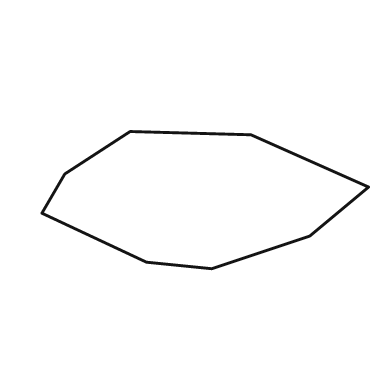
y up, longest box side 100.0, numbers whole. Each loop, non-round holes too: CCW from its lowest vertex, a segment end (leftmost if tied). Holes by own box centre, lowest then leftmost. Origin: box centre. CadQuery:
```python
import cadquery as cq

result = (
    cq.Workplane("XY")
    .moveTo(2.0, -21.0)
    .lineTo(32.0, -11.0)
    .lineTo(50.0, 4.0)
    .lineTo(14.0, 20.0)
    .lineTo(-23.0, 21.0)
    .lineTo(-43.0, 8.0)
    .lineTo(-50.0, -4.0)
    .lineTo(-18.0, -19.0)
    .close()
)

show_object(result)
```